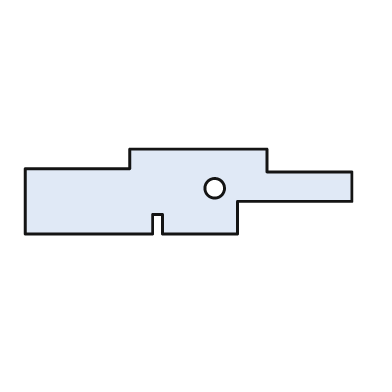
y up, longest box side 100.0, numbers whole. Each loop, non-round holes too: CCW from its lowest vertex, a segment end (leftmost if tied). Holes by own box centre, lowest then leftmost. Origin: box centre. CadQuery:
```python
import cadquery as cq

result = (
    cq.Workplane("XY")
    .moveTo(-50.0, -13.0)
    .lineTo(-11.0, -13.0)
    .lineTo(-11.0, -7.0)
    .lineTo(-8.0, -7.0)
    .lineTo(-8.0, -13.0)
    .lineTo(15.0, -13.0)
    .lineTo(15.0, -3.0)
    .lineTo(50.0, -3.0)
    .lineTo(50.0, 6.0)
    .lineTo(24.0, 6.0)
    .lineTo(24.0, 13.0)
    .lineTo(-18.0, 13.0)
    .lineTo(-18.0, 7.0)
    .lineTo(-50.0, 7.0)
    .close()
    .moveTo(8.0, 1.0)
    .circle(3.0)
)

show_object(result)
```